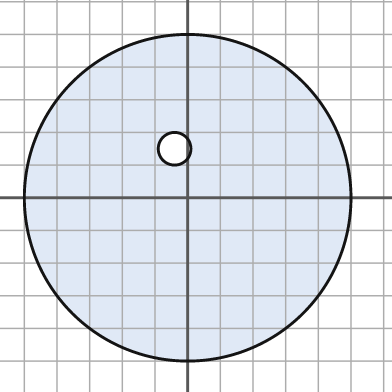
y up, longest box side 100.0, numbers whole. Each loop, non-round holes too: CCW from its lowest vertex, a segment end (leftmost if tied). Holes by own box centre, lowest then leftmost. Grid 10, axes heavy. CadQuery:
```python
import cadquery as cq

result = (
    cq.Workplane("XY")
    .moveTo(0.0, 0.0)
    .circle(50.0)
    .moveTo(-4.0, 15.0)
    .circle(5.0)
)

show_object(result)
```